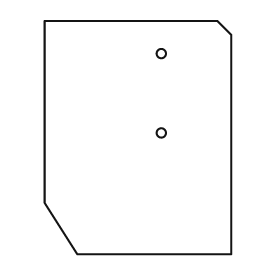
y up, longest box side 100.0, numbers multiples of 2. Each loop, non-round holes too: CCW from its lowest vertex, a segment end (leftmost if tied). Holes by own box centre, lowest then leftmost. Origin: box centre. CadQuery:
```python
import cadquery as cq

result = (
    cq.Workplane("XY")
    .moveTo(-26.0, -50.0)
    .lineTo(40.0, -50.0)
    .lineTo(40.0, 44.0)
    .lineTo(34.0, 50.0)
    .lineTo(-40.0, 50.0)
    .lineTo(-40.0, -28.0)
    .close()
    .moveTo(10.0, 2.0)
    .circle(2.0)
    .moveTo(10.0, 36.0)
    .circle(2.0)
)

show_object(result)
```